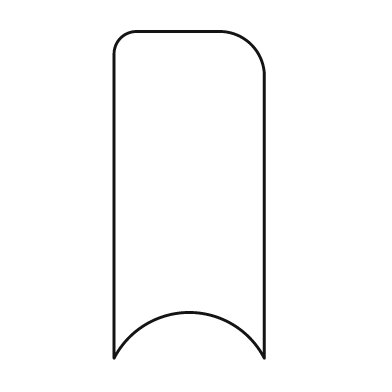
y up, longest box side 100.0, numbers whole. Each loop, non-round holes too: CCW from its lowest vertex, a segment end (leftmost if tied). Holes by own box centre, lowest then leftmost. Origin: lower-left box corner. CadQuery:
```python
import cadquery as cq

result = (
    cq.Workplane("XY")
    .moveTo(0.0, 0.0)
    .threePointArc((23.0, 14.0), (46.0, 0.0))
    .lineTo(46.0, 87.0)
    .threePointArc((42.0, 96.0), (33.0, 100.0))
    .lineTo(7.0, 100.0)
    .threePointArc((2.0, 98.0), (0.0, 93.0))
    .close()
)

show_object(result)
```